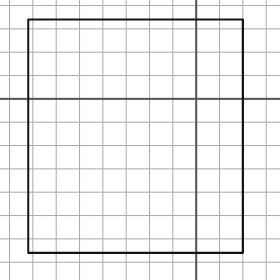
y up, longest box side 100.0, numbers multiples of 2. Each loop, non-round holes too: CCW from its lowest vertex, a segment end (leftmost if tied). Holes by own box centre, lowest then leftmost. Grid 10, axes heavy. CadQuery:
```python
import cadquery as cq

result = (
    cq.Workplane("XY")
    .moveTo(-72.0, -66.0)
    .lineTo(20.0, -66.0)
    .lineTo(20.0, 34.0)
    .lineTo(-72.0, 34.0)
    .close()
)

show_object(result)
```